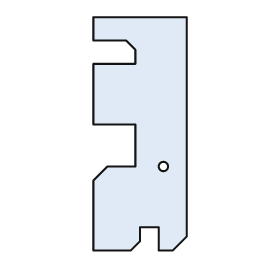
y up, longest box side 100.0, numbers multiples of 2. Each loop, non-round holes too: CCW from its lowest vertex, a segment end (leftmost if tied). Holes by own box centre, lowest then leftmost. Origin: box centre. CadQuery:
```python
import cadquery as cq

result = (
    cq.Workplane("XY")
    .moveTo(-20.0, -50.0)
    .lineTo(-4.0, -50.0)
    .lineTo(0.0, -46.0)
    .lineTo(0.0, -40.0)
    .lineTo(8.0, -40.0)
    .lineTo(8.0, -50.0)
    .lineTo(14.0, -50.0)
    .lineTo(20.0, -44.0)
    .lineTo(20.0, 50.0)
    .lineTo(-20.0, 50.0)
    .lineTo(-20.0, 40.0)
    .lineTo(-6.0, 40.0)
    .lineTo(-2.0, 36.0)
    .lineTo(-2.0, 30.0)
    .lineTo(-20.0, 30.0)
    .lineTo(-20.0, 4.0)
    .lineTo(-2.0, 4.0)
    .lineTo(-2.0, -14.0)
    .lineTo(-14.0, -14.0)
    .lineTo(-20.0, -20.0)
    .close()
    .moveTo(10.0, -14.0)
    .circle(2.0)
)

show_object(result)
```